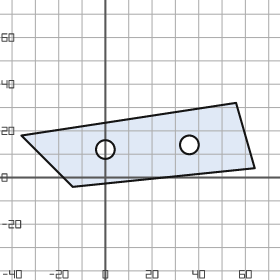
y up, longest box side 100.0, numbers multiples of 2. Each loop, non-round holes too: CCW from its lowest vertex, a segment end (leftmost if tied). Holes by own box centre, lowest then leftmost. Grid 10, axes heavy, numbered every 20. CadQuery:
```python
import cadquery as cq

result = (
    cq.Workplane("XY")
    .moveTo(-14.0, -4.0)
    .lineTo(64.0, 4.0)
    .lineTo(56.0, 32.0)
    .lineTo(-36.0, 18.0)
    .close()
    .moveTo(0.0, 12.0)
    .circle(4.0)
    .moveTo(36.0, 14.0)
    .circle(4.0)
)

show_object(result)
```